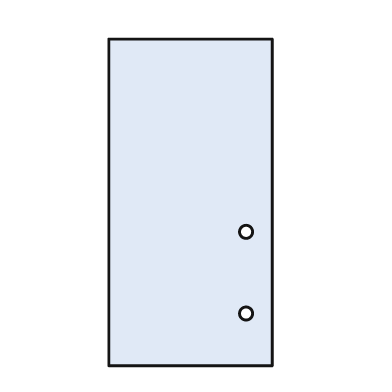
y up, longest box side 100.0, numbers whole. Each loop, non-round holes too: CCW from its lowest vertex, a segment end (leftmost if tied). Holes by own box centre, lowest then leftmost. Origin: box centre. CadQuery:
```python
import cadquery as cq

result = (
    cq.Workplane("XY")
    .moveTo(-25.0, -50.0)
    .lineTo(25.0, -50.0)
    .lineTo(25.0, 50.0)
    .lineTo(-25.0, 50.0)
    .close()
    .moveTo(17.0, -34.0)
    .circle(2.0)
    .moveTo(17.0, -9.0)
    .circle(2.0)
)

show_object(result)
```